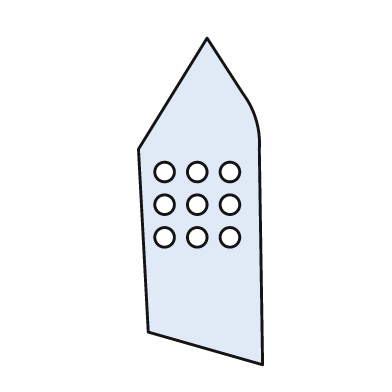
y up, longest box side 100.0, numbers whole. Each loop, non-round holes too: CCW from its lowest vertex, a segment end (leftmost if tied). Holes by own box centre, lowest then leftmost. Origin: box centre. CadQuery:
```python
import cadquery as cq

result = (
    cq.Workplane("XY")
    .moveTo(19.0, -50.0)
    .lineTo(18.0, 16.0)
    .threePointArc((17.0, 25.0), (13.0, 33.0))
    .lineTo(2.0, 50.0)
    .lineTo(-19.0, 16.0)
    .lineTo(-16.0, -40.0)
    .close()
    .moveTo(-11.0, -11.0)
    .circle(3.0)
    .moveTo(-1.0, -11.0)
    .circle(3.0)
    .moveTo(9.0, -11.0)
    .circle(3.0)
    .moveTo(-11.0, -1.0)
    .circle(3.0)
    .moveTo(-1.0, -1.0)
    .circle(3.0)
    .moveTo(9.0, -1.0)
    .circle(3.0)
    .moveTo(-11.0, 9.0)
    .circle(3.0)
    .moveTo(-1.0, 9.0)
    .circle(3.0)
    .moveTo(9.0, 9.0)
    .circle(3.0)
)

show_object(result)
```